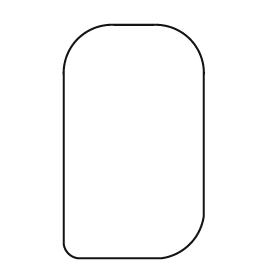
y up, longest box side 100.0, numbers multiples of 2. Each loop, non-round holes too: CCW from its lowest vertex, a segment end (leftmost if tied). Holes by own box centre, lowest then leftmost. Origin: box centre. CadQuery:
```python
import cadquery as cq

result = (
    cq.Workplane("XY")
    .moveTo(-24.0, -50.0)
    .lineTo(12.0, -50.0)
    .threePointArc((24.0, -44.0), (30.0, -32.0))
    .lineTo(30.0, 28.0)
    .threePointArc((24.0, 44.0), (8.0, 50.0))
    .lineTo(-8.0, 50.0)
    .threePointArc((-24.0, 44.0), (-30.0, 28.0))
    .lineTo(-30.0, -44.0)
    .threePointArc((-28.0, -48.0), (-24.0, -50.0))
    .close()
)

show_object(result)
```